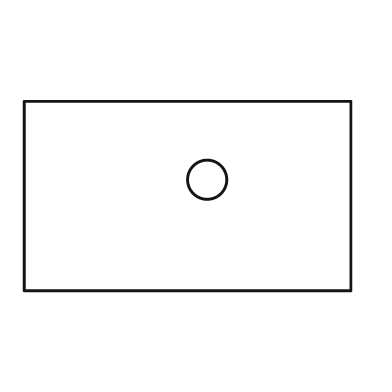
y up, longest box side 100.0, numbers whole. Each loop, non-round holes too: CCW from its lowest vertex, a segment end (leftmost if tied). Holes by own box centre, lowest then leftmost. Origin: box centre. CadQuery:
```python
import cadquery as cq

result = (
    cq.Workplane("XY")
    .moveTo(-50.0, -29.0)
    .lineTo(50.0, -29.0)
    .lineTo(50.0, 29.0)
    .lineTo(-50.0, 29.0)
    .close()
    .moveTo(6.0, 5.0)
    .circle(6.0)
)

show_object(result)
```